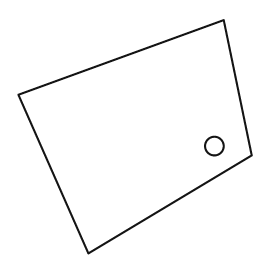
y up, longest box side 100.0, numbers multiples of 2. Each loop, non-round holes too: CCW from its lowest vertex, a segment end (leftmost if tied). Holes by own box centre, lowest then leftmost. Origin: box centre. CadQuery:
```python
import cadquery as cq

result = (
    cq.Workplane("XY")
    .moveTo(-20.0, -50.0)
    .lineTo(50.0, -8.0)
    .lineTo(38.0, 50.0)
    .lineTo(-50.0, 18.0)
    .close()
    .moveTo(34.0, -4.0)
    .circle(4.0)
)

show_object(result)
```